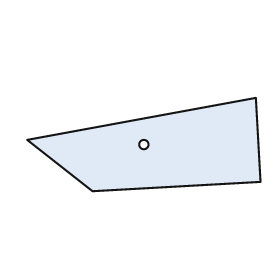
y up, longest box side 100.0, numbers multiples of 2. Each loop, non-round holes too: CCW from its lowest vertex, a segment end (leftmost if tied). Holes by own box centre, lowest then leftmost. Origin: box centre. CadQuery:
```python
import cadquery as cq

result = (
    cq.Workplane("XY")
    .moveTo(-22.0, -20.0)
    .lineTo(50.0, -16.0)
    .lineTo(48.0, 20.0)
    .lineTo(-50.0, 2.0)
    .close()
    .moveTo(0.0, 0.0)
    .circle(2.0)
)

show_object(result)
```